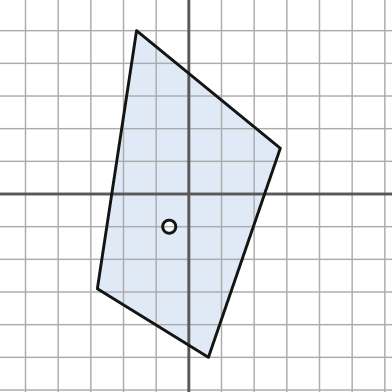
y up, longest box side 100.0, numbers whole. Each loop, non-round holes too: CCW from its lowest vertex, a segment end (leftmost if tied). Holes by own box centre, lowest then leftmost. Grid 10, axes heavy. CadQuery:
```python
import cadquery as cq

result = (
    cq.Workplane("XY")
    .moveTo(6.0, -50.0)
    .lineTo(28.0, 14.0)
    .lineTo(-16.0, 50.0)
    .lineTo(-28.0, -29.0)
    .close()
    .moveTo(-6.0, -10.0)
    .circle(2.0)
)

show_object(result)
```